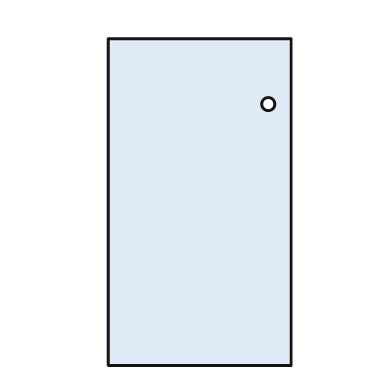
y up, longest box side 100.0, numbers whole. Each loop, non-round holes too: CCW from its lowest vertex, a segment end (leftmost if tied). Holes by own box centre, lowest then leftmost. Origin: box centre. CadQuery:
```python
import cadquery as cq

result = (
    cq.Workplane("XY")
    .moveTo(-28.0, -50.0)
    .lineTo(28.0, -50.0)
    .lineTo(28.0, 50.0)
    .lineTo(-28.0, 50.0)
    .close()
    .moveTo(21.0, 30.0)
    .circle(2.0)
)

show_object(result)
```